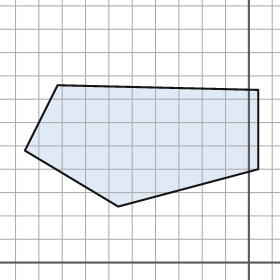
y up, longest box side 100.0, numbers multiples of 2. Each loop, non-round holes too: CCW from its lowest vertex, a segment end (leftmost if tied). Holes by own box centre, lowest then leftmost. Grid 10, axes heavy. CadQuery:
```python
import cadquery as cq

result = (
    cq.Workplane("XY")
    .moveTo(-56.0, 24.0)
    .lineTo(4.0, 40.0)
    .lineTo(4.0, 74.0)
    .lineTo(-82.0, 76.0)
    .lineTo(-96.0, 48.0)
    .close()
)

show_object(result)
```